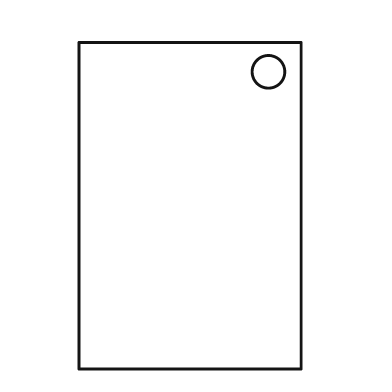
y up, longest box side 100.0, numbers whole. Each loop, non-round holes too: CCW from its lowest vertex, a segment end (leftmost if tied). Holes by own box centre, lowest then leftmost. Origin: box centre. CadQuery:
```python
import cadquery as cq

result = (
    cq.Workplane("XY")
    .moveTo(-34.0, -50.0)
    .lineTo(34.0, -50.0)
    .lineTo(34.0, 50.0)
    .lineTo(-34.0, 50.0)
    .close()
    .moveTo(24.0, 41.0)
    .circle(5.0)
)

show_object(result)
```